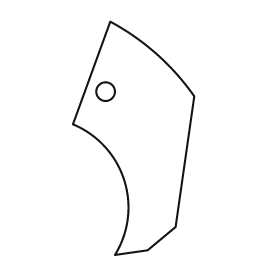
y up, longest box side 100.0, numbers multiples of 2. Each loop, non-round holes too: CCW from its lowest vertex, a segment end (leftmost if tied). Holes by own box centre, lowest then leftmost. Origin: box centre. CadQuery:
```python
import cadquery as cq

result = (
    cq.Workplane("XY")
    .moveTo(-8.0, -50.0)
    .lineTo(6.0, -48.0)
    .lineTo(18.0, -38.0)
    .lineTo(26.0, 18.0)
    .threePointArc((10.0, 36.0), (-10.0, 50.0))
    .lineTo(-26.0, 6.0)
    .threePointArc((-4.0, -18.0), (-8.0, -50.0))
    .close()
    .moveTo(-12.0, 20.0)
    .circle(4.0)
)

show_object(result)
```